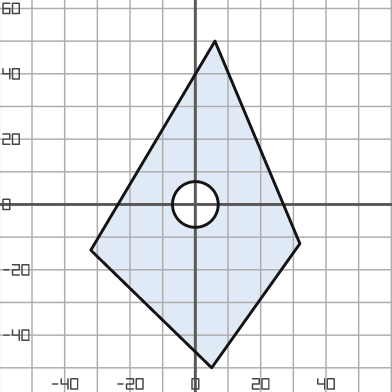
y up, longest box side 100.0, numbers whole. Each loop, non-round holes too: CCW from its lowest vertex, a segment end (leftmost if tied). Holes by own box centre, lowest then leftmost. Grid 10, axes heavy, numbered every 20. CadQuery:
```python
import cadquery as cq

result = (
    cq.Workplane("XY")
    .moveTo(5.0, -50.0)
    .lineTo(32.0, -12.0)
    .lineTo(6.0, 50.0)
    .lineTo(-32.0, -14.0)
    .close()
    .moveTo(0.0, 0.0)
    .circle(7.0)
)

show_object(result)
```